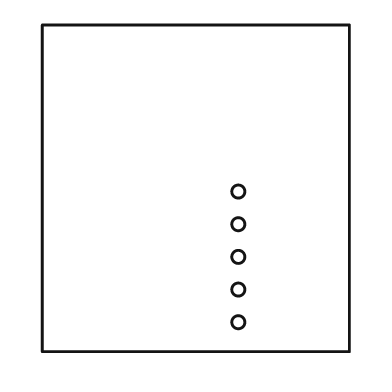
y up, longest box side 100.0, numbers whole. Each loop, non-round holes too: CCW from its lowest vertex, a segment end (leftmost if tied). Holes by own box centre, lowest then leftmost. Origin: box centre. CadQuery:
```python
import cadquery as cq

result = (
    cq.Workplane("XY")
    .moveTo(-47.0, -50.0)
    .lineTo(47.0, -50.0)
    .lineTo(47.0, 50.0)
    .lineTo(-47.0, 50.0)
    .close()
    .moveTo(13.0, -41.0)
    .circle(2.0)
    .moveTo(13.0, -31.0)
    .circle(2.0)
    .moveTo(13.0, -21.0)
    .circle(2.0)
    .moveTo(13.0, -11.0)
    .circle(2.0)
    .moveTo(13.0, -1.0)
    .circle(2.0)
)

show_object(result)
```